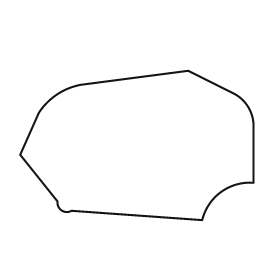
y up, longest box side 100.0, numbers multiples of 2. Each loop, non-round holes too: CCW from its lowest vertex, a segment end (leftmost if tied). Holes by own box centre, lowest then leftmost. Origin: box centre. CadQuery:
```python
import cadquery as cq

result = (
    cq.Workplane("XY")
    .moveTo(28.0, -32.0)
    .threePointArc((36.0, -20.0), (50.0, -16.0))
    .lineTo(50.0, 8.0)
    .threePointArc((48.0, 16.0), (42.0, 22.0))
    .lineTo(22.0, 32.0)
    .lineTo(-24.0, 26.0)
    .threePointArc((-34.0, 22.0), (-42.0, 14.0))
    .lineTo(-50.0, -4.0)
    .lineTo(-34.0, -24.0)
    .threePointArc((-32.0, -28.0), (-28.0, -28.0))
    .close()
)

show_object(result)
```